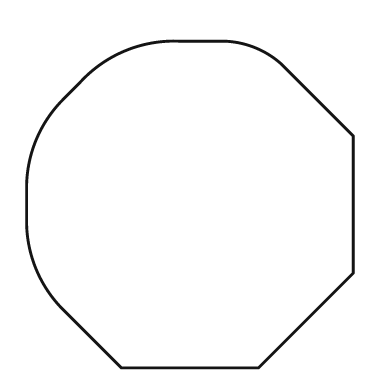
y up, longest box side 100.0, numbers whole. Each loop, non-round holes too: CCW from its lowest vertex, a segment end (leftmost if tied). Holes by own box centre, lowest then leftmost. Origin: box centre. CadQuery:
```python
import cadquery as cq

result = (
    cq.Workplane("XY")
    .moveTo(-21.0, -50.0)
    .lineTo(21.0, -50.0)
    .lineTo(50.0, -21.0)
    .lineTo(50.0, 21.0)
    .lineTo(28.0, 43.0)
    .threePointArc((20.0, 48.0), (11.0, 50.0))
    .lineTo(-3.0, 50.0)
    .threePointArc((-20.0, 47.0), (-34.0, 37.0))
    .lineTo(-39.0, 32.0)
    .threePointArc((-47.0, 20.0), (-50.0, 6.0))
    .lineTo(-50.0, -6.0)
    .threePointArc((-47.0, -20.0), (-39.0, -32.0))
    .close()
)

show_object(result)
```